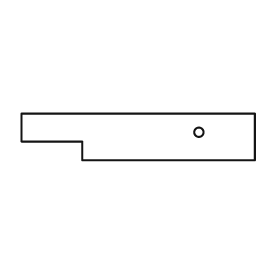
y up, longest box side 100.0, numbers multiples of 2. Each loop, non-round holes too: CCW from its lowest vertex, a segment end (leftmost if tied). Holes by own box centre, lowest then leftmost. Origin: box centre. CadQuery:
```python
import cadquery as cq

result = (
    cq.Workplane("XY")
    .moveTo(-24.0, -10.0)
    .lineTo(50.0, -10.0)
    .lineTo(50.0, 10.0)
    .lineTo(-50.0, 10.0)
    .lineTo(-50.0, -2.0)
    .lineTo(-24.0, -2.0)
    .close()
    .moveTo(26.0, 2.0)
    .circle(2.0)
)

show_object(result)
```